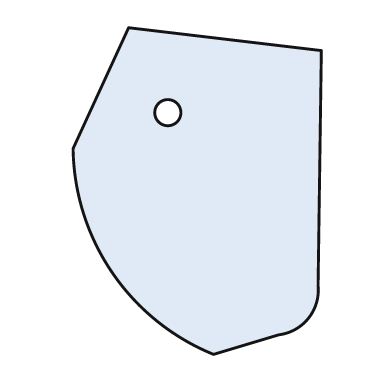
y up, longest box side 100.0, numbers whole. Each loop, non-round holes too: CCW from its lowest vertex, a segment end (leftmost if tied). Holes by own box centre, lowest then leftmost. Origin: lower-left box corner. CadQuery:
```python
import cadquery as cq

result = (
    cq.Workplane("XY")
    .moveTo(43.0, 0.0)
    .lineTo(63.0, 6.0)
    .threePointArc((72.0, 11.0), (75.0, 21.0))
    .lineTo(76.0, 93.0)
    .lineTo(17.0, 100.0)
    .lineTo(0.0, 63.0)
    .threePointArc((12.0, 25.0), (43.0, 0.0))
    .close()
    .moveTo(29.0, 74.0)
    .circle(4.0)
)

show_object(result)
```